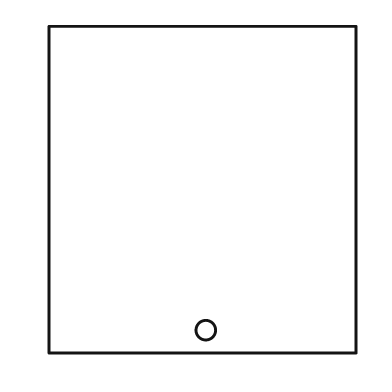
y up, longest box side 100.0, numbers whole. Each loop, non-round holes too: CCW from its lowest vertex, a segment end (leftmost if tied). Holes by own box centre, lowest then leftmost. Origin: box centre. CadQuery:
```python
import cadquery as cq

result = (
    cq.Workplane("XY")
    .moveTo(-47.0, -50.0)
    .lineTo(47.0, -50.0)
    .lineTo(47.0, 50.0)
    .lineTo(-47.0, 50.0)
    .close()
    .moveTo(1.0, -43.0)
    .circle(3.0)
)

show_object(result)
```